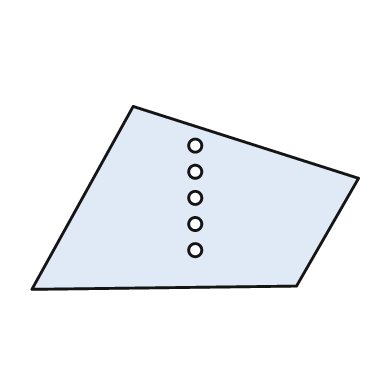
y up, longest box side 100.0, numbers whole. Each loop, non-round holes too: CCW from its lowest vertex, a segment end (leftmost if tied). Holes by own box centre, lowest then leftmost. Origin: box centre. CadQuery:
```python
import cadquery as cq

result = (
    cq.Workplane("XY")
    .moveTo(-50.0, -28.0)
    .lineTo(31.0, -27.0)
    .lineTo(50.0, 6.0)
    .lineTo(-19.0, 28.0)
    .close()
    .moveTo(0.0, -16.0)
    .circle(2.0)
    .moveTo(0.0, -8.0)
    .circle(2.0)
    .moveTo(0.0, 0.0)
    .circle(2.0)
    .moveTo(0.0, 8.0)
    .circle(2.0)
    .moveTo(0.0, 16.0)
    .circle(2.0)
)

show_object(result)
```